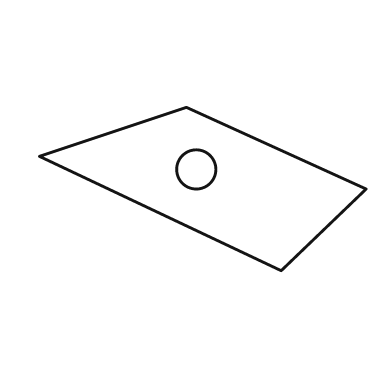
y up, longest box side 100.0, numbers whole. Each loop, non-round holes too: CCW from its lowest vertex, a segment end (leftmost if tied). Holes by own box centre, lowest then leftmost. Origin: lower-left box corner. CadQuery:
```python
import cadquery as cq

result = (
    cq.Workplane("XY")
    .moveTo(74.0, 0.0)
    .lineTo(100.0, 25.0)
    .lineTo(45.0, 50.0)
    .lineTo(0.0, 35.0)
    .close()
    .moveTo(48.0, 31.0)
    .circle(6.0)
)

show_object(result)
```